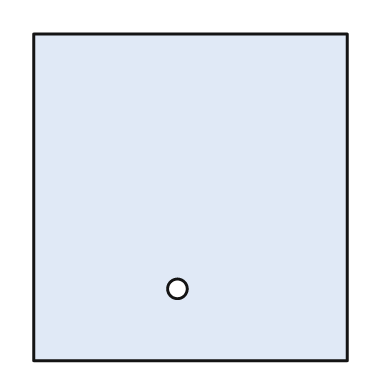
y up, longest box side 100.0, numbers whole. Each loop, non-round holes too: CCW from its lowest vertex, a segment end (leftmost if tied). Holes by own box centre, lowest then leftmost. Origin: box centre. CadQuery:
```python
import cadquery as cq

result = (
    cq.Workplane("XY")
    .moveTo(-48.0, -50.0)
    .lineTo(48.0, -50.0)
    .lineTo(48.0, 50.0)
    .lineTo(-48.0, 50.0)
    .close()
    .moveTo(-4.0, -28.0)
    .circle(3.0)
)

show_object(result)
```